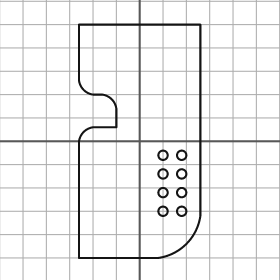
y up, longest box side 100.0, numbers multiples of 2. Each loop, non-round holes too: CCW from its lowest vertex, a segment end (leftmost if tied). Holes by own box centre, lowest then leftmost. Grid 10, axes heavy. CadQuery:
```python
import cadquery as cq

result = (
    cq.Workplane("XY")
    .moveTo(-26.0, -50.0)
    .lineTo(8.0, -50.0)
    .threePointArc((20.0, -44.0), (26.0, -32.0))
    .lineTo(26.0, 50.0)
    .lineTo(-26.0, 50.0)
    .lineTo(-26.0, 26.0)
    .threePointArc((-24.0, 22.0), (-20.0, 20.0))
    .lineTo(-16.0, 20.0)
    .threePointArc((-12.0, 18.0), (-10.0, 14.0))
    .lineTo(-10.0, 6.0)
    .lineTo(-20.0, 6.0)
    .threePointArc((-24.0, 4.0), (-26.0, 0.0))
    .close()
    .moveTo(10.0, -30.0)
    .circle(2.0)
    .moveTo(18.0, -30.0)
    .circle(2.0)
    .moveTo(10.0, -22.0)
    .circle(2.0)
    .moveTo(18.0, -22.0)
    .circle(2.0)
    .moveTo(10.0, -14.0)
    .circle(2.0)
    .moveTo(18.0, -14.0)
    .circle(2.0)
    .moveTo(10.0, -6.0)
    .circle(2.0)
    .moveTo(18.0, -6.0)
    .circle(2.0)
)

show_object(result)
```